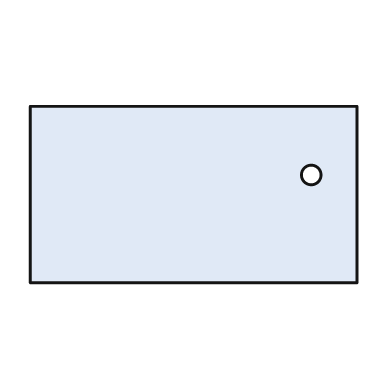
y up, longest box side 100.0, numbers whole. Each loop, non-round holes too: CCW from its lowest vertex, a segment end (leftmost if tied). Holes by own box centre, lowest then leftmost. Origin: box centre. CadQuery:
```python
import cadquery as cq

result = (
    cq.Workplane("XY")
    .moveTo(-50.0, -27.0)
    .lineTo(50.0, -27.0)
    .lineTo(50.0, 27.0)
    .lineTo(-50.0, 27.0)
    .close()
    .moveTo(36.0, 6.0)
    .circle(3.0)
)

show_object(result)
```